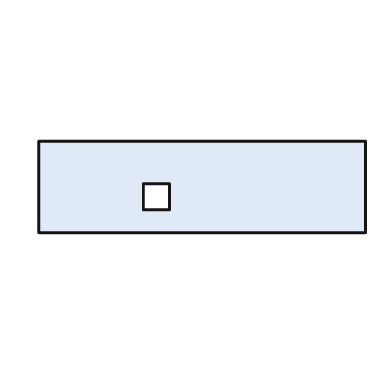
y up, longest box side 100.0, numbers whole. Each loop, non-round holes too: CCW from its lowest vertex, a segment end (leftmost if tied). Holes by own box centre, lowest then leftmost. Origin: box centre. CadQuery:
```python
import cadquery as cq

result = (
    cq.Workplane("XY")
    .moveTo(-50.0, -14.0)
    .lineTo(50.0, -14.0)
    .lineTo(50.0, 14.0)
    .lineTo(-50.0, 14.0)
    .close()
    .moveTo(-18.0, -7.0)
    .lineTo(-10.0, -7.0)
    .lineTo(-10.0, 1.0)
    .lineTo(-18.0, 1.0)
    .close()
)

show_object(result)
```